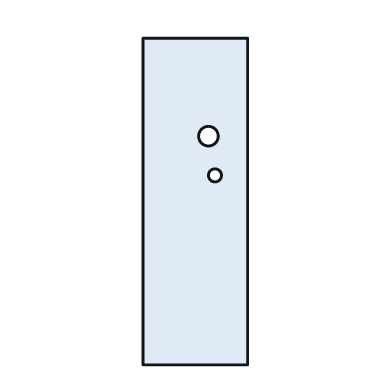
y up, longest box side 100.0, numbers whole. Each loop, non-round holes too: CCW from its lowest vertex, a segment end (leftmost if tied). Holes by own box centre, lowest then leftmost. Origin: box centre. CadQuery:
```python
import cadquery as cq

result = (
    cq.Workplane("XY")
    .moveTo(-16.0, -50.0)
    .lineTo(16.0, -50.0)
    .lineTo(16.0, 50.0)
    .lineTo(-16.0, 50.0)
    .close()
    .moveTo(6.0, 8.0)
    .circle(2.0)
    .moveTo(4.0, 20.0)
    .circle(3.0)
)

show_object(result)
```